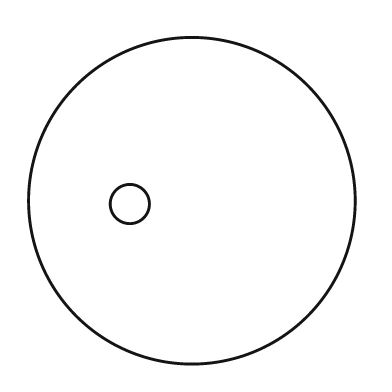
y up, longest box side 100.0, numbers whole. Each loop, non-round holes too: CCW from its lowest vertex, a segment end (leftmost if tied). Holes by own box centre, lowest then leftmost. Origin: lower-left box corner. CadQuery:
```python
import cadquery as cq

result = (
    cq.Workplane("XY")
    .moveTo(50.0, 50.0)
    .circle(50.0)
    .moveTo(31.0, 49.0)
    .circle(6.0)
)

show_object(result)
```